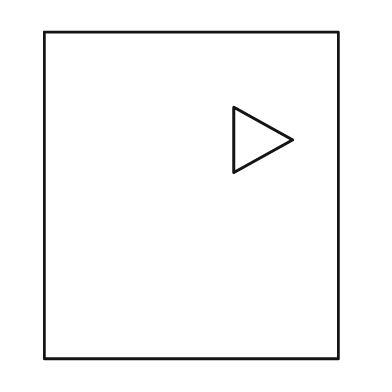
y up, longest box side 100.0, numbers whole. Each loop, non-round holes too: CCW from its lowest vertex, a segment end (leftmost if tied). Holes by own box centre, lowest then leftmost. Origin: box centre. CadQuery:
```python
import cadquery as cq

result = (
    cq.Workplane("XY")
    .moveTo(-45.0, -50.0)
    .lineTo(45.0, -50.0)
    .lineTo(45.0, 50.0)
    .lineTo(-45.0, 50.0)
    .close()
    .moveTo(13.0, 7.0)
    .lineTo(31.0, 17.0)
    .lineTo(13.0, 27.0)
    .close()
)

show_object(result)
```